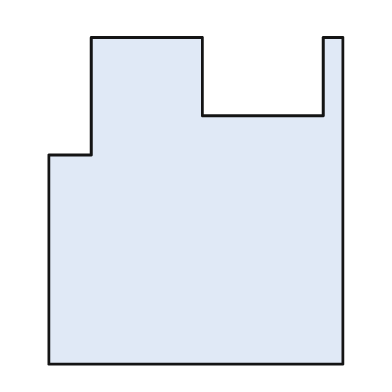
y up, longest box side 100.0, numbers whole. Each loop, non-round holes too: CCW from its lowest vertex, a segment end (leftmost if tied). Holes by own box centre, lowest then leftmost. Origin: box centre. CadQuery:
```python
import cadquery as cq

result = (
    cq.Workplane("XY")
    .moveTo(-45.0, -50.0)
    .lineTo(45.0, -50.0)
    .lineTo(45.0, 50.0)
    .lineTo(39.0, 50.0)
    .lineTo(39.0, 26.0)
    .lineTo(2.0, 26.0)
    .lineTo(2.0, 50.0)
    .lineTo(-32.0, 50.0)
    .lineTo(-32.0, 14.0)
    .lineTo(-45.0, 14.0)
    .close()
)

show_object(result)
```